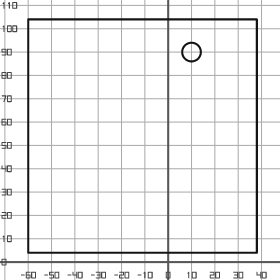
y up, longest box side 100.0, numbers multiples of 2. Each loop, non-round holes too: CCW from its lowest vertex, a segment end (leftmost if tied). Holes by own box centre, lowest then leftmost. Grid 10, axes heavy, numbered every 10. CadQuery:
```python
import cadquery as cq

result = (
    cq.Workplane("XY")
    .moveTo(-60.0, 4.0)
    .lineTo(38.0, 4.0)
    .lineTo(38.0, 104.0)
    .lineTo(-60.0, 104.0)
    .close()
    .moveTo(10.0, 90.0)
    .circle(4.0)
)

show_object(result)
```